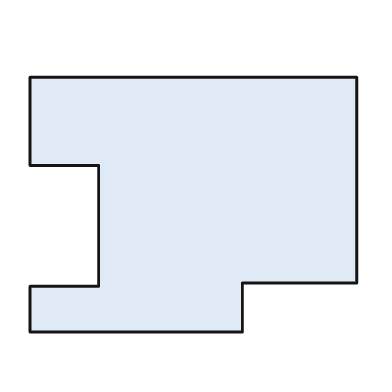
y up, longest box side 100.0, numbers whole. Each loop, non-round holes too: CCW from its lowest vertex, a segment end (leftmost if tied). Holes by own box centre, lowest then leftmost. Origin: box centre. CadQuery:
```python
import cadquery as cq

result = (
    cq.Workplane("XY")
    .moveTo(-50.0, -39.0)
    .lineTo(15.0, -39.0)
    .lineTo(15.0, -24.0)
    .lineTo(50.0, -24.0)
    .lineTo(50.0, 39.0)
    .lineTo(-50.0, 39.0)
    .lineTo(-50.0, 12.0)
    .lineTo(-29.0, 12.0)
    .lineTo(-29.0, -25.0)
    .lineTo(-50.0, -25.0)
    .close()
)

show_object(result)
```